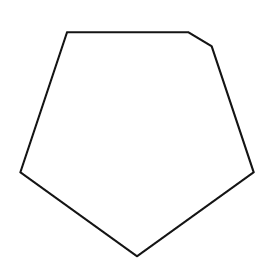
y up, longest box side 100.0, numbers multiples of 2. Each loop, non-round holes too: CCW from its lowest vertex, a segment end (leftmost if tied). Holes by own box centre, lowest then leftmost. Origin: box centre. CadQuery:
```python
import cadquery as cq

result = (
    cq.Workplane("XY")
    .moveTo(0.0, -48.0)
    .lineTo(50.0, -12.0)
    .lineTo(32.0, 42.0)
    .lineTo(22.0, 48.0)
    .lineTo(-30.0, 48.0)
    .lineTo(-50.0, -12.0)
    .close()
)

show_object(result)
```